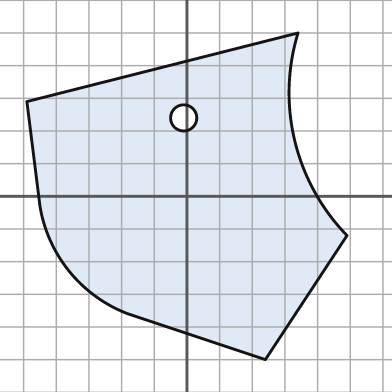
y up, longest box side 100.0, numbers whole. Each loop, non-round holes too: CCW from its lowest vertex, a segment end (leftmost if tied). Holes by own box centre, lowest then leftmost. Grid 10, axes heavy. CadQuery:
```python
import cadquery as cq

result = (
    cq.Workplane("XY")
    .moveTo(24.0, -50.0)
    .lineTo(49.0, -12.0)
    .threePointArc((33.0, 17.0), (34.0, 50.0))
    .lineTo(-49.0, 29.0)
    .lineTo(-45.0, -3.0)
    .threePointArc((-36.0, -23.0), (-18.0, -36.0))
    .close()
    .moveTo(-1.0, 24.0)
    .circle(4.0)
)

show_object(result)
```